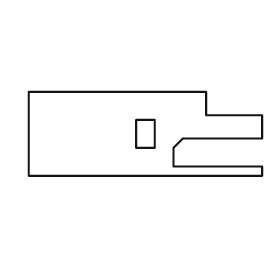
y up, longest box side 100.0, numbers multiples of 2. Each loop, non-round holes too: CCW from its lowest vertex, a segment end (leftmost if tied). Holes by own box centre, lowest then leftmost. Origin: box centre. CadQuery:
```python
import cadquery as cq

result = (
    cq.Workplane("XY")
    .moveTo(-50.0, -18.0)
    .lineTo(50.0, -18.0)
    .lineTo(50.0, -14.0)
    .lineTo(12.0, -14.0)
    .lineTo(12.0, -6.0)
    .lineTo(16.0, -2.0)
    .lineTo(50.0, -2.0)
    .lineTo(50.0, 8.0)
    .lineTo(26.0, 8.0)
    .lineTo(26.0, 18.0)
    .lineTo(-50.0, 18.0)
    .close()
    .moveTo(-4.0, -6.0)
    .lineTo(4.0, -6.0)
    .lineTo(4.0, 6.0)
    .lineTo(-4.0, 6.0)
    .close()
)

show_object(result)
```